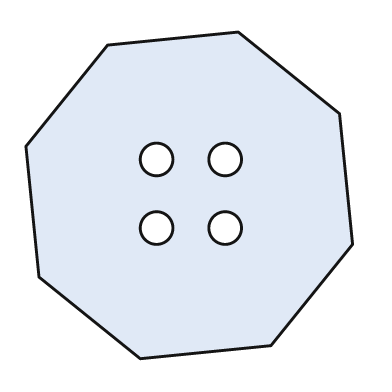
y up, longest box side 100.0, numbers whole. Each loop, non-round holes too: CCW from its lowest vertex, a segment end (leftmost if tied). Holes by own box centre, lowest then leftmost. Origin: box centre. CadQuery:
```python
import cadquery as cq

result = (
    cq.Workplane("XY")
    .moveTo(-15.0, -50.0)
    .lineTo(25.0, -46.0)
    .lineTo(50.0, -15.0)
    .lineTo(46.0, 25.0)
    .lineTo(15.0, 50.0)
    .lineTo(-25.0, 46.0)
    .lineTo(-50.0, 15.0)
    .lineTo(-46.0, -25.0)
    .close()
    .moveTo(-10.0, -10.0)
    .circle(5.0)
    .moveTo(11.0, -10.0)
    .circle(5.0)
    .moveTo(-10.0, 11.0)
    .circle(5.0)
    .moveTo(11.0, 11.0)
    .circle(5.0)
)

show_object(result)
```